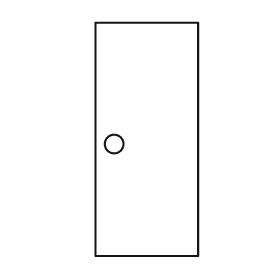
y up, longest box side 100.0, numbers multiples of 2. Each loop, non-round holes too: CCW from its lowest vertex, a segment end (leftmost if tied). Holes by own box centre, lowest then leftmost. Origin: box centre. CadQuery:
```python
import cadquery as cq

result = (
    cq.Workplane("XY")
    .moveTo(-22.0, -50.0)
    .lineTo(22.0, -50.0)
    .lineTo(22.0, 50.0)
    .lineTo(-22.0, 50.0)
    .close()
    .moveTo(-14.0, -2.0)
    .circle(4.0)
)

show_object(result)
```